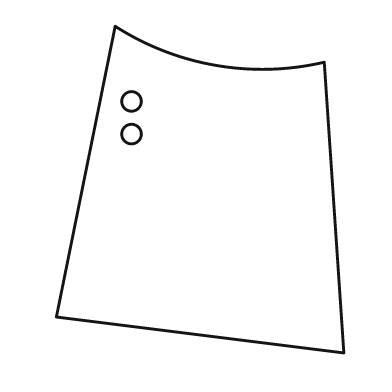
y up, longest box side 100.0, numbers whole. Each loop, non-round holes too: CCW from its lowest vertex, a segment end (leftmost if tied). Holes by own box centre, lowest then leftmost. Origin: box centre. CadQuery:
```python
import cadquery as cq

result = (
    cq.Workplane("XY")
    .moveTo(44.0, -50.0)
    .lineTo(38.0, 39.0)
    .threePointArc((5.0, 38.0), (-26.0, 50.0))
    .lineTo(-44.0, -39.0)
    .close()
    .moveTo(-21.0, 17.0)
    .circle(3.0)
    .moveTo(-21.0, 27.0)
    .circle(3.0)
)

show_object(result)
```